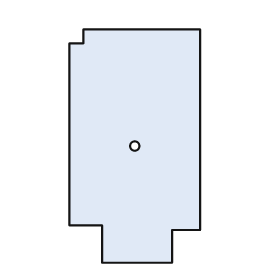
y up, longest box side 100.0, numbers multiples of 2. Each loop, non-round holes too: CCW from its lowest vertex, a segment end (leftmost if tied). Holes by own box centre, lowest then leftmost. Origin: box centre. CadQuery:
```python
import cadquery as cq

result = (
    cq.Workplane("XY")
    .moveTo(-14.0, -50.0)
    .lineTo(16.0, -50.0)
    .lineTo(16.0, -36.0)
    .lineTo(28.0, -36.0)
    .lineTo(28.0, 50.0)
    .lineTo(-22.0, 50.0)
    .lineTo(-22.0, 44.0)
    .lineTo(-28.0, 44.0)
    .lineTo(-28.0, -34.0)
    .lineTo(-14.0, -34.0)
    .close()
    .moveTo(0.0, 0.0)
    .circle(2.0)
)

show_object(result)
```